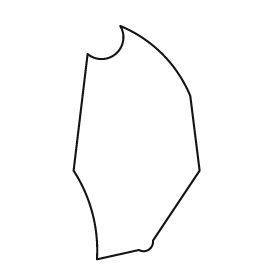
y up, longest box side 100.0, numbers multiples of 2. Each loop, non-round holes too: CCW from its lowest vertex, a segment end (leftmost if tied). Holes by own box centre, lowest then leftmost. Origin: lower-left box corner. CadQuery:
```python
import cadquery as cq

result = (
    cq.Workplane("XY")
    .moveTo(10.0, 0.0)
    .lineTo(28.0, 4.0)
    .threePointArc((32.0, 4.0), (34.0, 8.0))
    .lineTo(54.0, 38.0)
    .lineTo(50.0, 70.0)
    .threePointArc((38.0, 88.0), (20.0, 100.0))
    .threePointArc((18.0, 88.0), (6.0, 88.0))
    .lineTo(0.0, 38.0)
    .threePointArc((8.0, 20.0), (10.0, 0.0))
    .close()
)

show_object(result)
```